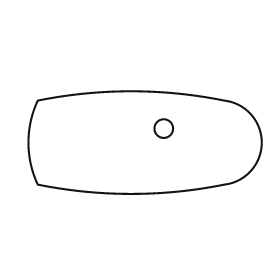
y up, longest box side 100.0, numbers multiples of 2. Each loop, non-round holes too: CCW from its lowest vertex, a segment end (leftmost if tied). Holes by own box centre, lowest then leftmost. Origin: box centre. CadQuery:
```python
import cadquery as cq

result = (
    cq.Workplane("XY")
    .moveTo(-46.0, -18.0)
    .threePointArc((-6.0, -22.0), (34.0, -18.0))
    .threePointArc((50.0, 0.0), (34.0, 18.0))
    .threePointArc((-6.0, 22.0), (-46.0, 18.0))
    .threePointArc((-50.0, 0.0), (-46.0, -18.0))
    .close()
    .moveTo(8.0, 6.0)
    .circle(4.0)
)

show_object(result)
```